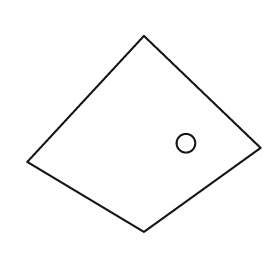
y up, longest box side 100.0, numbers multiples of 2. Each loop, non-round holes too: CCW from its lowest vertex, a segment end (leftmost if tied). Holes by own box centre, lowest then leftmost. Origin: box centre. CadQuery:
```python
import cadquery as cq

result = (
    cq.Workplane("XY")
    .moveTo(0.0, -42.0)
    .lineTo(50.0, -6.0)
    .lineTo(0.0, 42.0)
    .lineTo(-50.0, -12.0)
    .close()
    .moveTo(18.0, -4.0)
    .circle(4.0)
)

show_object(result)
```